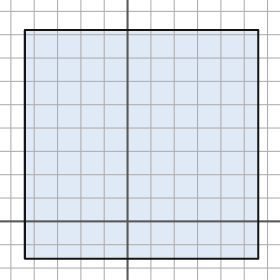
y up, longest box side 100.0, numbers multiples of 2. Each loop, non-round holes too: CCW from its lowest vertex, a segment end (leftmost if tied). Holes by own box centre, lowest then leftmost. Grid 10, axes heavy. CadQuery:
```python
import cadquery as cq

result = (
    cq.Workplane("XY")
    .moveTo(-44.0, -16.0)
    .lineTo(56.0, -16.0)
    .lineTo(56.0, 82.0)
    .lineTo(-44.0, 82.0)
    .close()
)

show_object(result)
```